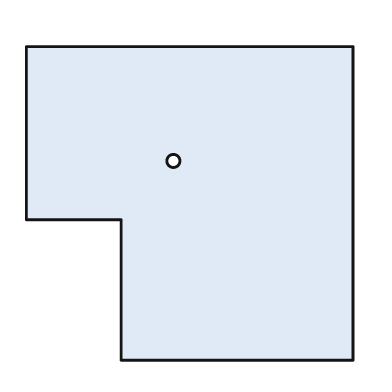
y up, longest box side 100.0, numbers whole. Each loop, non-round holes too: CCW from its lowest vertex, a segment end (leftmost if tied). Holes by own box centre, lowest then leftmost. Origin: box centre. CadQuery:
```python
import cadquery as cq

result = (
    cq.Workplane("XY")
    .moveTo(-21.0, -48.0)
    .lineTo(50.0, -48.0)
    .lineTo(50.0, 48.0)
    .lineTo(-50.0, 48.0)
    .lineTo(-50.0, -5.0)
    .lineTo(-21.0, -5.0)
    .close()
    .moveTo(-5.0, 13.0)
    .circle(2.0)
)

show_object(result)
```